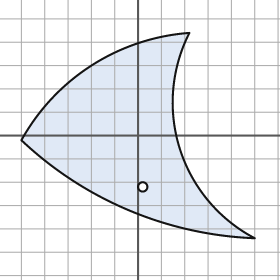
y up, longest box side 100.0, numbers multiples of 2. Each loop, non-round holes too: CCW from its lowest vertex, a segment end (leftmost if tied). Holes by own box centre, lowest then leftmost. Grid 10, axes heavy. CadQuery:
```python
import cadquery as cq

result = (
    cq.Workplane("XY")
    .moveTo(50.0, -44.0)
    .threePointArc((18.0, -6.0), (22.0, 44.0))
    .threePointArc((-20.0, 30.0), (-50.0, -2.0))
    .threePointArc((-4.0, -32.0), (50.0, -44.0))
    .close()
    .moveTo(2.0, -22.0)
    .circle(2.0)
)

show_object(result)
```